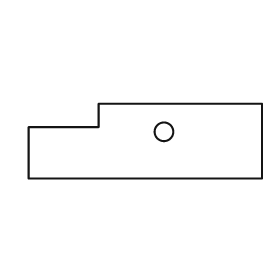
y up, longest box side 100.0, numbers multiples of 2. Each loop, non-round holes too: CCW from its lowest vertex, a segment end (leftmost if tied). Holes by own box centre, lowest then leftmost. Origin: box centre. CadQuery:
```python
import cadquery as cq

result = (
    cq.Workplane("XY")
    .moveTo(-50.0, -16.0)
    .lineTo(50.0, -16.0)
    .lineTo(50.0, 16.0)
    .lineTo(-20.0, 16.0)
    .lineTo(-20.0, 6.0)
    .lineTo(-50.0, 6.0)
    .close()
    .moveTo(8.0, 4.0)
    .circle(4.0)
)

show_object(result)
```